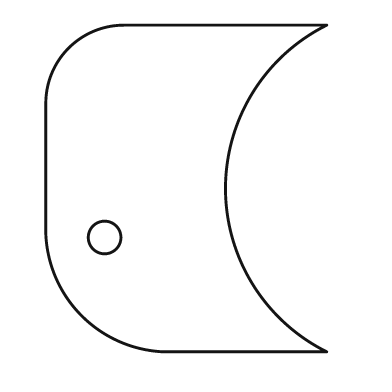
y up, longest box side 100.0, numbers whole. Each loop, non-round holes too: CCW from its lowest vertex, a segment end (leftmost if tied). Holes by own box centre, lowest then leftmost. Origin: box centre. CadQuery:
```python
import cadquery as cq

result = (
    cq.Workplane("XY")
    .moveTo(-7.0, -50.0)
    .lineTo(43.0, -50.0)
    .threePointArc((12.0, 0.0), (43.0, 50.0))
    .lineTo(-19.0, 50.0)
    .threePointArc((-36.0, 43.0), (-43.0, 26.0))
    .lineTo(-43.0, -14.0)
    .threePointArc((-32.0, -39.0), (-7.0, -50.0))
    .close()
    .moveTo(-25.0, -15.0)
    .circle(5.0)
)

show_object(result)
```